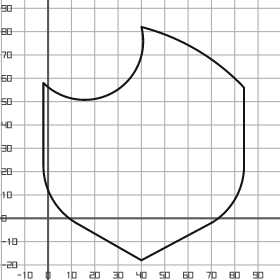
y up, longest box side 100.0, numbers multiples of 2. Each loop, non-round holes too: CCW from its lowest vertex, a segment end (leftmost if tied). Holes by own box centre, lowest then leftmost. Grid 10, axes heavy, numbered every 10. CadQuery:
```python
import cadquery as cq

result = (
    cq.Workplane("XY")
    .moveTo(40.0, -18.0)
    .lineTo(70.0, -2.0)
    .threePointArc((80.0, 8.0), (84.0, 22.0))
    .lineTo(84.0, 56.0)
    .threePointArc((64.0, 72.0), (40.0, 82.0))
    .threePointArc((28.0, 54.0), (-2.0, 58.0))
    .lineTo(-2.0, 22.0)
    .threePointArc((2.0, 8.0), (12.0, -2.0))
    .close()
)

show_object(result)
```